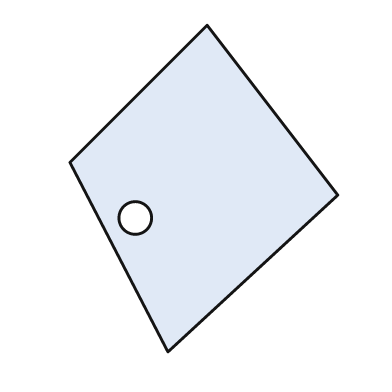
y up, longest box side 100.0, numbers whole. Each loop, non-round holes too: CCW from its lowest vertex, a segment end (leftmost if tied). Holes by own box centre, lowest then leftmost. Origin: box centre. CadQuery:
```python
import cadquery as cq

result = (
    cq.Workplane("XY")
    .moveTo(-11.0, -50.0)
    .lineTo(41.0, -2.0)
    .lineTo(1.0, 50.0)
    .lineTo(-41.0, 8.0)
    .close()
    .moveTo(-21.0, -9.0)
    .circle(5.0)
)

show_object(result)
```